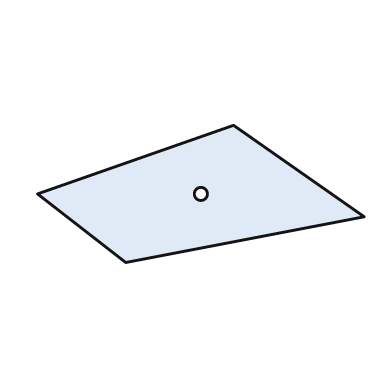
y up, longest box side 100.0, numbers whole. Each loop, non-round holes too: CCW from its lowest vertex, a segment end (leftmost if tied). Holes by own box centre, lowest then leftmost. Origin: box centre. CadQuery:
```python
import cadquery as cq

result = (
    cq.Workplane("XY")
    .moveTo(-23.0, -21.0)
    .lineTo(50.0, -7.0)
    .lineTo(10.0, 21.0)
    .lineTo(-50.0, 0.0)
    .close()
    .moveTo(0.0, 0.0)
    .circle(2.0)
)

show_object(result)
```